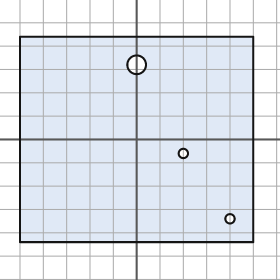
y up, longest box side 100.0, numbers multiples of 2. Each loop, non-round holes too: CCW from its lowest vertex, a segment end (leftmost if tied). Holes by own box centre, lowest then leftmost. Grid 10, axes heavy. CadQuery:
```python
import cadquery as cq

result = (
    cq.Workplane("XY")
    .moveTo(-50.0, -44.0)
    .lineTo(50.0, -44.0)
    .lineTo(50.0, 44.0)
    .lineTo(-50.0, 44.0)
    .close()
    .moveTo(40.0, -34.0)
    .circle(2.0)
    .moveTo(20.0, -6.0)
    .circle(2.0)
    .moveTo(0.0, 32.0)
    .circle(4.0)
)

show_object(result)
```